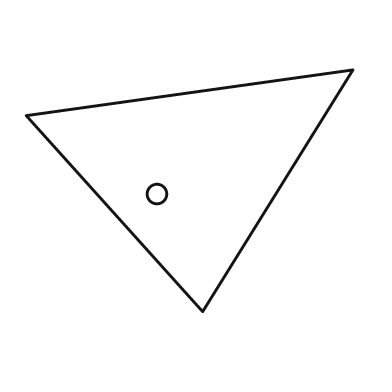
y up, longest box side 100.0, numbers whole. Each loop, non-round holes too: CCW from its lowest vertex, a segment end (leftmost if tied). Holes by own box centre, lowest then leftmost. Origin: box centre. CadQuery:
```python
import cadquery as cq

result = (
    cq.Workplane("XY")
    .moveTo(4.0, -37.0)
    .lineTo(50.0, 37.0)
    .lineTo(-50.0, 23.0)
    .close()
    .moveTo(-10.0, -1.0)
    .circle(3.0)
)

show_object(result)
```